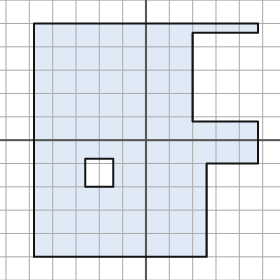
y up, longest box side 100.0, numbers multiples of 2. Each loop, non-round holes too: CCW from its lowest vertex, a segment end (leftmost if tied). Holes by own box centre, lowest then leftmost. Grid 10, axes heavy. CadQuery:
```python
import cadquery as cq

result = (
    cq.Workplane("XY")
    .moveTo(-48.0, -50.0)
    .lineTo(26.0, -50.0)
    .lineTo(26.0, -10.0)
    .lineTo(48.0, -10.0)
    .lineTo(48.0, 8.0)
    .lineTo(20.0, 8.0)
    .lineTo(20.0, 46.0)
    .lineTo(48.0, 46.0)
    .lineTo(48.0, 50.0)
    .lineTo(-48.0, 50.0)
    .close()
    .moveTo(-26.0, -20.0)
    .lineTo(-14.0, -20.0)
    .lineTo(-14.0, -8.0)
    .lineTo(-26.0, -8.0)
    .close()
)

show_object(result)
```